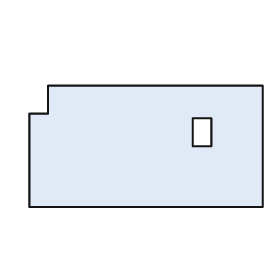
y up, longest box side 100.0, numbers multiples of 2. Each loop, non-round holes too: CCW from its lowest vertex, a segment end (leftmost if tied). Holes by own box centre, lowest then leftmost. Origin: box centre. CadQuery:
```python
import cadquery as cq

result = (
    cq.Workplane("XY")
    .moveTo(-50.0, -26.0)
    .lineTo(50.0, -26.0)
    .lineTo(50.0, 26.0)
    .lineTo(-42.0, 26.0)
    .lineTo(-42.0, 14.0)
    .lineTo(-50.0, 14.0)
    .close()
    .moveTo(20.0, 0.0)
    .lineTo(28.0, 0.0)
    .lineTo(28.0, 12.0)
    .lineTo(20.0, 12.0)
    .close()
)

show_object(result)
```